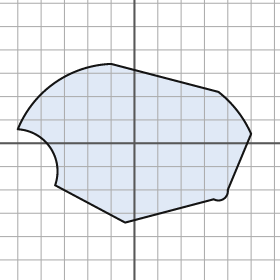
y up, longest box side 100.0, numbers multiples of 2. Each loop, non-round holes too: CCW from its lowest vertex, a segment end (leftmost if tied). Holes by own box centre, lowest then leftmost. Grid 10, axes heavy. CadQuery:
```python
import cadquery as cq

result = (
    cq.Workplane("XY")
    .moveTo(-4.0, -34.0)
    .lineTo(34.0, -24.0)
    .threePointArc((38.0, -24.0), (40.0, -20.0))
    .lineTo(50.0, 4.0)
    .threePointArc((44.0, 14.0), (36.0, 22.0))
    .lineTo(-10.0, 34.0)
    .threePointArc((-34.0, 26.0), (-50.0, 6.0))
    .threePointArc((-36.0, -2.0), (-34.0, -18.0))
    .close()
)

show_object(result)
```